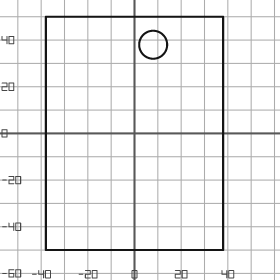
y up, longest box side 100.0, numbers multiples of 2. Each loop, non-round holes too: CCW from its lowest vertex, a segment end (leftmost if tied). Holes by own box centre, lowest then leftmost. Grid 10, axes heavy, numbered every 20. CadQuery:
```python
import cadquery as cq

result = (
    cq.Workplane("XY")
    .moveTo(-38.0, -50.0)
    .lineTo(38.0, -50.0)
    .lineTo(38.0, 50.0)
    .lineTo(-38.0, 50.0)
    .close()
    .moveTo(8.0, 38.0)
    .circle(6.0)
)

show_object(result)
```